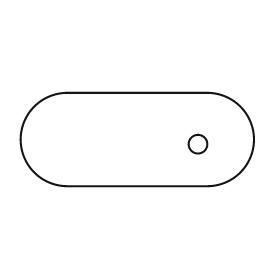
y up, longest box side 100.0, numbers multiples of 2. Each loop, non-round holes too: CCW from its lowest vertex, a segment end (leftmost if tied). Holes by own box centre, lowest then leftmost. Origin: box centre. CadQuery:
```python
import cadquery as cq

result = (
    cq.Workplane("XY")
    .moveTo(-30.0, -20.0)
    .lineTo(30.0, -20.0)
    .threePointArc((50.0, 0.0), (30.0, 20.0))
    .lineTo(-30.0, 20.0)
    .threePointArc((-50.0, 0.0), (-30.0, -20.0))
    .close()
    .moveTo(26.0, -2.0)
    .circle(4.0)
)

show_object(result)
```